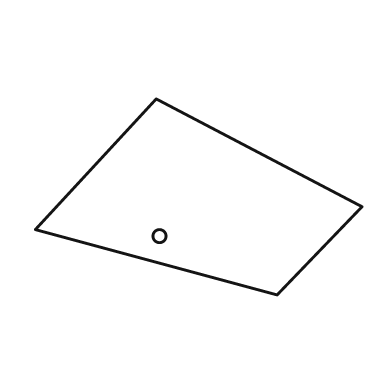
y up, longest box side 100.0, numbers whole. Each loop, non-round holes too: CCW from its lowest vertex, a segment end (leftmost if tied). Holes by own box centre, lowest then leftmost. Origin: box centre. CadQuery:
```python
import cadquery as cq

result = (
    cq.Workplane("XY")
    .moveTo(24.0, -30.0)
    .lineTo(50.0, -3.0)
    .lineTo(-13.0, 30.0)
    .lineTo(-50.0, -10.0)
    .close()
    .moveTo(-12.0, -12.0)
    .circle(2.0)
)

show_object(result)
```